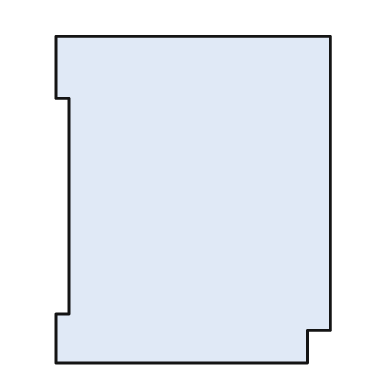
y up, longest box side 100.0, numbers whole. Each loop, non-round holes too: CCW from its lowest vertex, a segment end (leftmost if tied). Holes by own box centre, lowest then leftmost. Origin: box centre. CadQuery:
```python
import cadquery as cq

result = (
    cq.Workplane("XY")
    .moveTo(-42.0, -50.0)
    .lineTo(35.0, -50.0)
    .lineTo(35.0, -40.0)
    .lineTo(42.0, -40.0)
    .lineTo(42.0, 50.0)
    .lineTo(-42.0, 50.0)
    .lineTo(-42.0, 31.0)
    .lineTo(-38.0, 31.0)
    .lineTo(-38.0, -35.0)
    .lineTo(-42.0, -35.0)
    .close()
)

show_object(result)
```